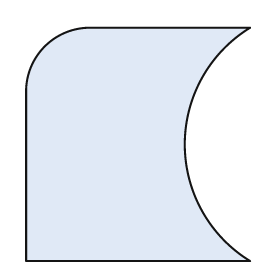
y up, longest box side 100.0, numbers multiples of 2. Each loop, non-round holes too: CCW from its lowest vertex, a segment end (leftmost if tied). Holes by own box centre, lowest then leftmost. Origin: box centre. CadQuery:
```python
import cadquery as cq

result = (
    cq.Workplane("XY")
    .moveTo(-48.0, -50.0)
    .lineTo(48.0, -50.0)
    .threePointArc((20.0, 0.0), (48.0, 50.0))
    .lineTo(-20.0, 50.0)
    .threePointArc((-40.0, 42.0), (-48.0, 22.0))
    .close()
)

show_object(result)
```